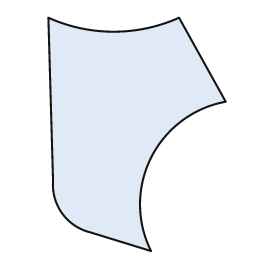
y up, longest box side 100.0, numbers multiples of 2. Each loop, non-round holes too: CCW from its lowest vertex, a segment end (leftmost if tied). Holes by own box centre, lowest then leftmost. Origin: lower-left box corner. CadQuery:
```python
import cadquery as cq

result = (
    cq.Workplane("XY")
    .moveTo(44.0, 0.0)
    .threePointArc((44.0, 40.0), (76.0, 64.0))
    .lineTo(56.0, 100.0)
    .threePointArc((28.0, 94.0), (0.0, 100.0))
    .lineTo(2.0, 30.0)
    .threePointArc((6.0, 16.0), (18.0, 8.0))
    .close()
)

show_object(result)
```